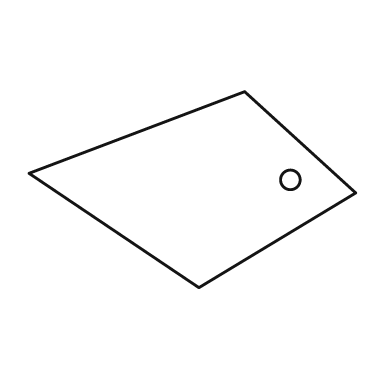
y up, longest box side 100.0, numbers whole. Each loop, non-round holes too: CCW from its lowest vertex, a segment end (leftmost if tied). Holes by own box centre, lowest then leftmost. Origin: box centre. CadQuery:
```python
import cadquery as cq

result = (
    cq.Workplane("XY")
    .moveTo(2.0, -30.0)
    .lineTo(50.0, -1.0)
    .lineTo(16.0, 30.0)
    .lineTo(-50.0, 5.0)
    .close()
    .moveTo(30.0, 3.0)
    .circle(3.0)
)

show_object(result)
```